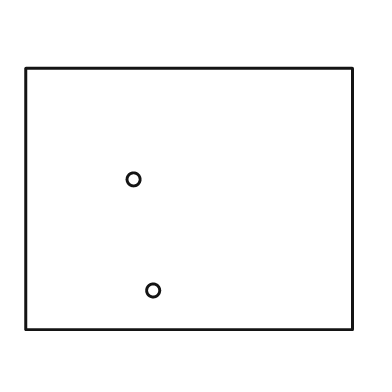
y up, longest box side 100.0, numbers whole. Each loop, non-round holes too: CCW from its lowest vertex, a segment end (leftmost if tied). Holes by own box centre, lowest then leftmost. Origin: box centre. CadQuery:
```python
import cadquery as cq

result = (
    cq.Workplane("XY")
    .moveTo(-50.0, -40.0)
    .lineTo(50.0, -40.0)
    .lineTo(50.0, 40.0)
    .lineTo(-50.0, 40.0)
    .close()
    .moveTo(-11.0, -28.0)
    .circle(2.0)
    .moveTo(-17.0, 6.0)
    .circle(2.0)
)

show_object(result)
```